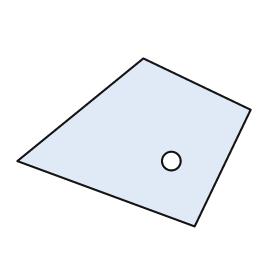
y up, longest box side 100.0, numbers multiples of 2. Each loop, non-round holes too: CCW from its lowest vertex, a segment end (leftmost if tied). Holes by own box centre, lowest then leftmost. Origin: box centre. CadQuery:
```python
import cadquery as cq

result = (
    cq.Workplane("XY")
    .moveTo(26.0, -36.0)
    .lineTo(50.0, 14.0)
    .lineTo(4.0, 36.0)
    .lineTo(-50.0, -8.0)
    .close()
    .moveTo(16.0, -8.0)
    .circle(4.0)
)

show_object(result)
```